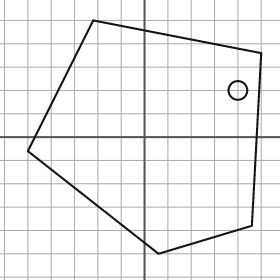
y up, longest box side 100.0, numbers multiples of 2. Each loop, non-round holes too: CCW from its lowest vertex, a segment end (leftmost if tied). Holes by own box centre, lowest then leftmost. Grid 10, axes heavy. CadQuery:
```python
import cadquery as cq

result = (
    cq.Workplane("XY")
    .moveTo(6.0, -50.0)
    .lineTo(46.0, -38.0)
    .lineTo(50.0, 36.0)
    .lineTo(-22.0, 50.0)
    .lineTo(-50.0, -6.0)
    .close()
    .moveTo(40.0, 20.0)
    .circle(4.0)
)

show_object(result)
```